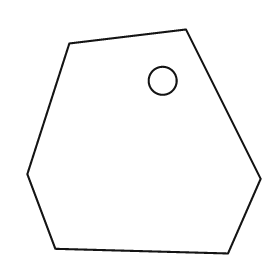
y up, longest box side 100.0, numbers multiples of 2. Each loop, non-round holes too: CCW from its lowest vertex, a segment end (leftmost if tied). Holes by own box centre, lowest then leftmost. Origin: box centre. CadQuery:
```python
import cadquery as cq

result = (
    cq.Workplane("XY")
    .moveTo(36.0, -48.0)
    .lineTo(50.0, -16.0)
    .lineTo(18.0, 48.0)
    .lineTo(-32.0, 42.0)
    .lineTo(-50.0, -14.0)
    .lineTo(-38.0, -46.0)
    .close()
    .moveTo(8.0, 26.0)
    .circle(6.0)
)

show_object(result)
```